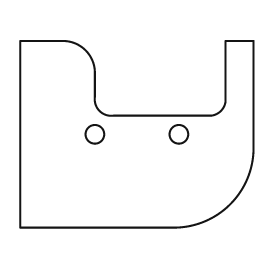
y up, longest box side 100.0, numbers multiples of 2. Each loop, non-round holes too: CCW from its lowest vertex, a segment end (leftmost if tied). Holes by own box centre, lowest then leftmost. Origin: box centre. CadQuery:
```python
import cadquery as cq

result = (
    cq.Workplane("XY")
    .moveTo(-50.0, -40.0)
    .lineTo(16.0, -40.0)
    .threePointArc((40.0, -30.0), (50.0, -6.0))
    .lineTo(50.0, 40.0)
    .lineTo(38.0, 40.0)
    .lineTo(38.0, 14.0)
    .threePointArc((36.0, 10.0), (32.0, 8.0))
    .lineTo(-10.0, 8.0)
    .threePointArc((-16.0, 10.0), (-18.0, 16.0))
    .lineTo(-18.0, 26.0)
    .threePointArc((-22.0, 36.0), (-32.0, 40.0))
    .lineTo(-50.0, 40.0)
    .close()
    .moveTo(-18.0, 0.0)
    .circle(4.0)
    .moveTo(18.0, 0.0)
    .circle(4.0)
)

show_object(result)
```